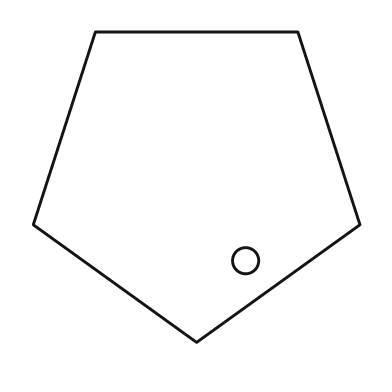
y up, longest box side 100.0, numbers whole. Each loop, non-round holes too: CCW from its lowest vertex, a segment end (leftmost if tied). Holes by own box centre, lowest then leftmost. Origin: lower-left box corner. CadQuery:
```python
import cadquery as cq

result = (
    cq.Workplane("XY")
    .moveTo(50.0, 0.0)
    .lineTo(100.0, 36.0)
    .lineTo(81.0, 95.0)
    .lineTo(19.0, 95.0)
    .lineTo(0.0, 36.0)
    .close()
    .moveTo(65.0, 25.0)
    .circle(4.0)
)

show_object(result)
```